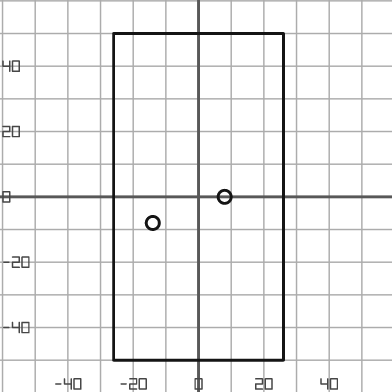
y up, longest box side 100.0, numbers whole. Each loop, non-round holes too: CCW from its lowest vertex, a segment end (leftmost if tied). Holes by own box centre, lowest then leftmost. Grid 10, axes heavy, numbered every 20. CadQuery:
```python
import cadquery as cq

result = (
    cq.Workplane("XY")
    .moveTo(-26.0, -50.0)
    .lineTo(26.0, -50.0)
    .lineTo(26.0, 50.0)
    .lineTo(-26.0, 50.0)
    .close()
    .moveTo(-14.0, -8.0)
    .circle(2.0)
    .moveTo(8.0, 0.0)
    .circle(2.0)
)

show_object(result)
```